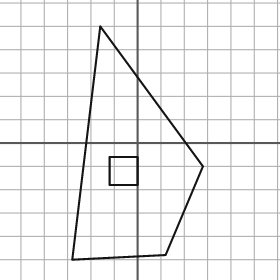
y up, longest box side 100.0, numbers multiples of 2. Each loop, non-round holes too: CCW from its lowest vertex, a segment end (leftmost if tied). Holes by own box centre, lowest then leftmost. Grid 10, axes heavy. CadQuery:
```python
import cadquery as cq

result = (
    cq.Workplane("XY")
    .moveTo(-28.0, -50.0)
    .lineTo(12.0, -48.0)
    .lineTo(28.0, -10.0)
    .lineTo(-16.0, 50.0)
    .close()
    .moveTo(-12.0, -18.0)
    .lineTo(0.0, -18.0)
    .lineTo(0.0, -6.0)
    .lineTo(-12.0, -6.0)
    .close()
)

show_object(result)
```